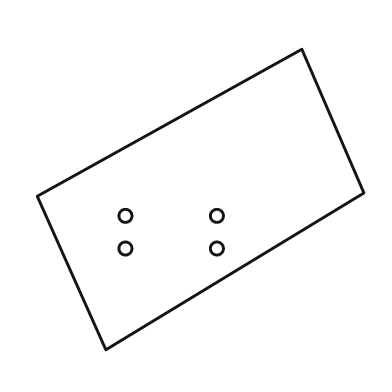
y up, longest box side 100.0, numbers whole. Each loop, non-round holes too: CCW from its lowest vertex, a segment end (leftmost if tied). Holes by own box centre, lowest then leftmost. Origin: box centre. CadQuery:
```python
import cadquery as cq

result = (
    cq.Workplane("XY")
    .moveTo(-29.0, -46.0)
    .lineTo(50.0, 2.0)
    .lineTo(31.0, 46.0)
    .lineTo(-50.0, 1.0)
    .close()
    .moveTo(-23.0, -15.0)
    .circle(2.0)
    .moveTo(5.0, -15.0)
    .circle(2.0)
    .moveTo(-23.0, -5.0)
    .circle(2.0)
    .moveTo(5.0, -5.0)
    .circle(2.0)
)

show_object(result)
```